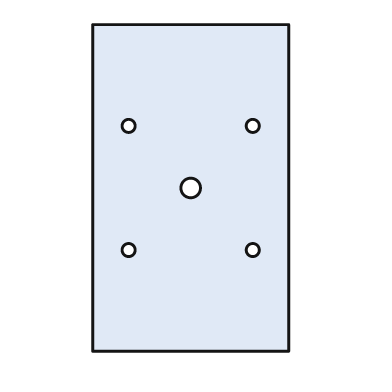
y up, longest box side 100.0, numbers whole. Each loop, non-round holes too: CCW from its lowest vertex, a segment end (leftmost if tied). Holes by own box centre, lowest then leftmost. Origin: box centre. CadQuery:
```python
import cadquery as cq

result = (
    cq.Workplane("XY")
    .moveTo(-30.0, -50.0)
    .lineTo(30.0, -50.0)
    .lineTo(30.0, 50.0)
    .lineTo(-30.0, 50.0)
    .close()
    .moveTo(-19.0, -19.0)
    .circle(2.0)
    .moveTo(19.0, -19.0)
    .circle(2.0)
    .moveTo(0.0, 0.0)
    .circle(3.0)
    .moveTo(-19.0, 19.0)
    .circle(2.0)
    .moveTo(19.0, 19.0)
    .circle(2.0)
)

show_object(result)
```